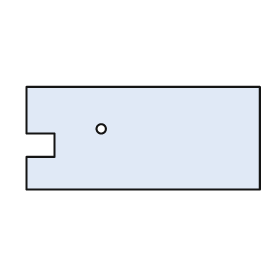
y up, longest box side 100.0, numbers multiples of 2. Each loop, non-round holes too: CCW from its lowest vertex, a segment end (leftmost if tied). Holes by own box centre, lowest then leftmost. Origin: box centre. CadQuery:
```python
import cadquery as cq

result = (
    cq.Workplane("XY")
    .moveTo(-50.0, -22.0)
    .lineTo(50.0, -22.0)
    .lineTo(50.0, 22.0)
    .lineTo(-50.0, 22.0)
    .lineTo(-50.0, 2.0)
    .lineTo(-38.0, 2.0)
    .lineTo(-38.0, -8.0)
    .lineTo(-50.0, -8.0)
    .close()
    .moveTo(-18.0, 4.0)
    .circle(2.0)
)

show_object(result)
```